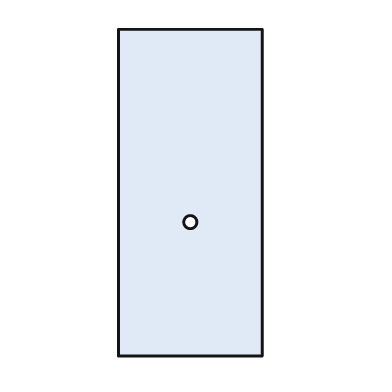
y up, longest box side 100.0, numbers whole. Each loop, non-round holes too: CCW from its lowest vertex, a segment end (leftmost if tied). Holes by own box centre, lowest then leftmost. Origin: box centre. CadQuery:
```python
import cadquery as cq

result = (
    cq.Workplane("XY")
    .moveTo(-22.0, -50.0)
    .lineTo(22.0, -50.0)
    .lineTo(22.0, 50.0)
    .lineTo(-22.0, 50.0)
    .close()
    .moveTo(0.0, -9.0)
    .circle(2.0)
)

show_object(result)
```